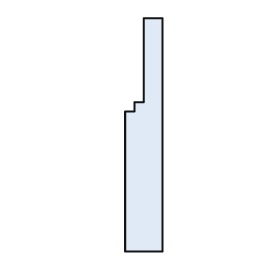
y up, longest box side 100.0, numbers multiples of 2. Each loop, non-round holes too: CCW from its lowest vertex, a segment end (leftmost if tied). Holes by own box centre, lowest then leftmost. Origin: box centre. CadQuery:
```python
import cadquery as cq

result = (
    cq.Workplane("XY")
    .moveTo(-8.0, -50.0)
    .lineTo(8.0, -50.0)
    .lineTo(8.0, 50.0)
    .lineTo(0.0, 50.0)
    .lineTo(0.0, 14.0)
    .lineTo(-4.0, 14.0)
    .lineTo(-4.0, 10.0)
    .lineTo(-8.0, 10.0)
    .close()
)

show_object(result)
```